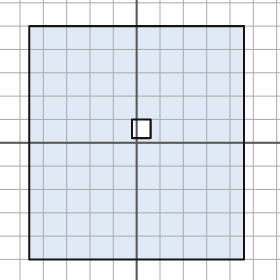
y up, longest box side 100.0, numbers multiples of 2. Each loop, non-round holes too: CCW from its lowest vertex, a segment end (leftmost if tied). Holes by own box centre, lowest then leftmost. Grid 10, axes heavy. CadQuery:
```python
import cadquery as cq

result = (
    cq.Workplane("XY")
    .moveTo(-46.0, -50.0)
    .lineTo(46.0, -50.0)
    .lineTo(46.0, 50.0)
    .lineTo(-46.0, 50.0)
    .close()
    .moveTo(-2.0, 2.0)
    .lineTo(6.0, 2.0)
    .lineTo(6.0, 10.0)
    .lineTo(-2.0, 10.0)
    .close()
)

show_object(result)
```